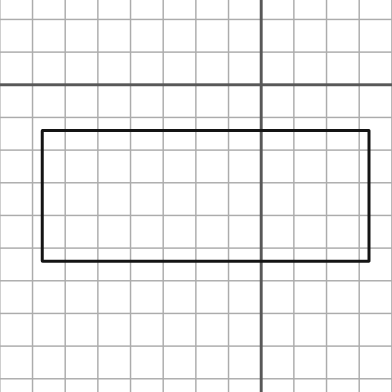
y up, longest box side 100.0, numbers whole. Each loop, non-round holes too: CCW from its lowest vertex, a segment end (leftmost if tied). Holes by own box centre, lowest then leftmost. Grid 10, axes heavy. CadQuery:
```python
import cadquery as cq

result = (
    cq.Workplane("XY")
    .moveTo(-67.0, -54.0)
    .lineTo(33.0, -54.0)
    .lineTo(33.0, -14.0)
    .lineTo(-67.0, -14.0)
    .close()
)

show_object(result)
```